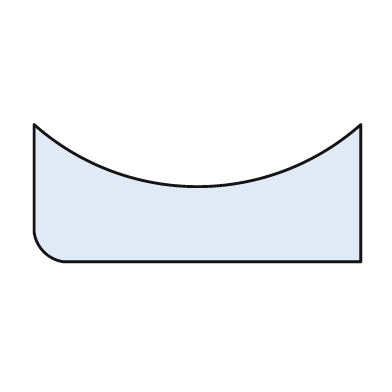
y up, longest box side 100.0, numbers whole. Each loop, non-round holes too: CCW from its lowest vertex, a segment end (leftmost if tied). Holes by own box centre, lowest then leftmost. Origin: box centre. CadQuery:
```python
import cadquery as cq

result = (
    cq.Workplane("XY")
    .moveTo(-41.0, -21.0)
    .lineTo(50.0, -21.0)
    .lineTo(50.0, 21.0)
    .threePointArc((0.0, 2.0), (-50.0, 21.0))
    .lineTo(-50.0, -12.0)
    .threePointArc((-47.0, -18.0), (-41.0, -21.0))
    .close()
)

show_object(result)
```